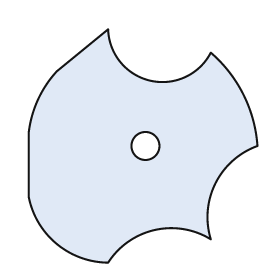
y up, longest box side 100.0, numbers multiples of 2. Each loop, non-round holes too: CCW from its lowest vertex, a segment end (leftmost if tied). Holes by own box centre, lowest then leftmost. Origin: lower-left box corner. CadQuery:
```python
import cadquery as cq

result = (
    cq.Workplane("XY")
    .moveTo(34.0, 0.0)
    .threePointArc((54.0, 14.0), (78.0, 10.0))
    .threePointArc((80.0, 34.0), (98.0, 50.0))
    .threePointArc((92.0, 72.0), (78.0, 90.0))
    .threePointArc((52.0, 78.0), (34.0, 100.0))
    .lineTo(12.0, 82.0)
    .threePointArc((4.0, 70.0), (0.0, 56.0))
    .lineTo(0.0, 28.0)
    .threePointArc((12.0, 8.0), (34.0, 0.0))
    .close()
    .moveTo(50.0, 50.0)
    .circle(6.0)
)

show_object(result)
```